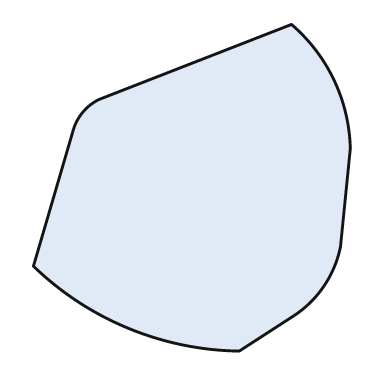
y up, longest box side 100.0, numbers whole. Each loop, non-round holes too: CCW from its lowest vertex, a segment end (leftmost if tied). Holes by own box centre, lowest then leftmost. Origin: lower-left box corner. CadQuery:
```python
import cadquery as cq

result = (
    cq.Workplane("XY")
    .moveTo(63.0, 0.0)
    .lineTo(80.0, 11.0)
    .threePointArc((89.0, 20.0), (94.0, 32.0))
    .lineTo(97.0, 62.0)
    .threePointArc((92.0, 83.0), (79.0, 100.0))
    .lineTo(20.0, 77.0)
    .threePointArc((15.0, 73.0), (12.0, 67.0))
    .lineTo(0.0, 26.0)
    .threePointArc((29.0, 7.0), (63.0, 0.0))
    .close()
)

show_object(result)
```